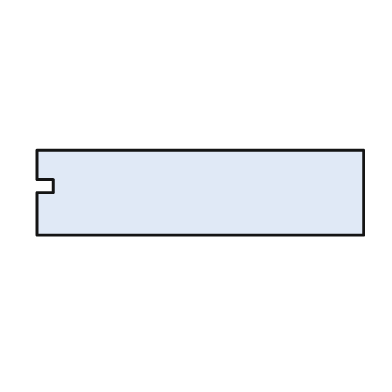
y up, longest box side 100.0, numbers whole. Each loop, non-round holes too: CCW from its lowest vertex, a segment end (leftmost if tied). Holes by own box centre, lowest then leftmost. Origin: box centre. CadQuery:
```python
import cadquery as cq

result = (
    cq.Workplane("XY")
    .moveTo(-50.0, -13.0)
    .lineTo(50.0, -13.0)
    .lineTo(50.0, 13.0)
    .lineTo(-50.0, 13.0)
    .lineTo(-50.0, 4.0)
    .lineTo(-45.0, 4.0)
    .lineTo(-45.0, 0.0)
    .lineTo(-50.0, 0.0)
    .close()
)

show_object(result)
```